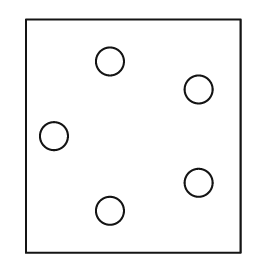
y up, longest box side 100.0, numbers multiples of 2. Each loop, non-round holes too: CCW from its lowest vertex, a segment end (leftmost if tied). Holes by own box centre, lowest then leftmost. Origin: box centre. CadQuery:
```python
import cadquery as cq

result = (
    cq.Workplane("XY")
    .moveTo(-46.0, -50.0)
    .lineTo(46.0, -50.0)
    .lineTo(46.0, 50.0)
    .lineTo(-46.0, 50.0)
    .close()
    .moveTo(-10.0, -32.0)
    .circle(6.0)
    .moveTo(28.0, -20.0)
    .circle(6.0)
    .moveTo(-34.0, 0.0)
    .circle(6.0)
    .moveTo(28.0, 20.0)
    .circle(6.0)
    .moveTo(-10.0, 32.0)
    .circle(6.0)
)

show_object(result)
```